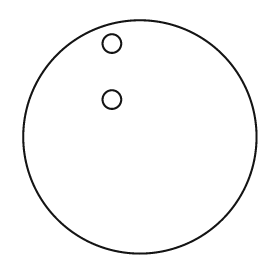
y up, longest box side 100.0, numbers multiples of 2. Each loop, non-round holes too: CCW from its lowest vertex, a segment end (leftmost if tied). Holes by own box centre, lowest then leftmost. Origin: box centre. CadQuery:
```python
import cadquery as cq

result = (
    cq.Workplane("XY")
    .moveTo(0.0, 0.0)
    .circle(50.0)
    .moveTo(-12.0, 16.0)
    .circle(4.0)
    .moveTo(-12.0, 40.0)
    .circle(4.0)
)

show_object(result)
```